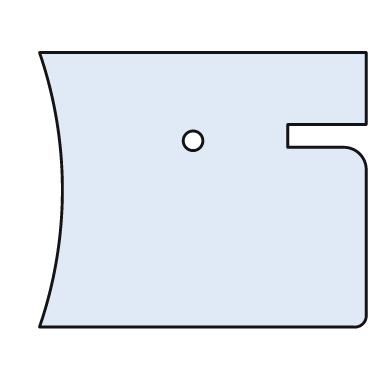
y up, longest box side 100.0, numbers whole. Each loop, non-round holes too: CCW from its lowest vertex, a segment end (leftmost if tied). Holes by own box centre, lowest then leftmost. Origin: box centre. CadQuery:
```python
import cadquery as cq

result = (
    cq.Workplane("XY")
    .moveTo(-50.0, -42.0)
    .lineTo(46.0, -42.0)
    .threePointArc((49.0, -41.0), (50.0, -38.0))
    .lineTo(50.0, 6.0)
    .threePointArc((48.0, 11.0), (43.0, 13.0))
    .lineTo(26.0, 13.0)
    .lineTo(26.0, 20.0)
    .lineTo(50.0, 20.0)
    .lineTo(50.0, 42.0)
    .lineTo(-50.0, 42.0)
    .threePointArc((-43.0, 0.0), (-50.0, -42.0))
    .close()
    .moveTo(-3.0, 15.0)
    .circle(3.0)
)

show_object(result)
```